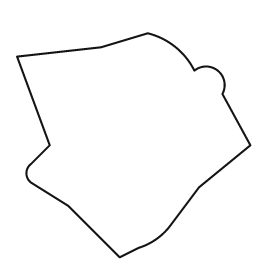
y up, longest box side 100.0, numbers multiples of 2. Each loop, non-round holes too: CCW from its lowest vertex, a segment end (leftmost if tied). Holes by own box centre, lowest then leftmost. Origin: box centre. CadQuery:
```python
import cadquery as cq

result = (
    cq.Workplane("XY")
    .moveTo(-6.0, -48.0)
    .lineTo(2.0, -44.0)
    .threePointArc((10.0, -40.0), (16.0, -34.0))
    .lineTo(28.0, -18.0)
    .lineTo(50.0, 0.0)
    .lineTo(38.0, 22.0)
    .threePointArc((36.0, 32.0), (26.0, 32.0))
    .threePointArc((18.0, 42.0), (6.0, 48.0))
    .lineTo(-14.0, 42.0)
    .lineTo(-50.0, 38.0)
    .lineTo(-36.0, 0.0)
    .lineTo(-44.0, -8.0)
    .threePointArc((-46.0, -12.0), (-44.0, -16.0))
    .lineTo(-28.0, -26.0)
    .close()
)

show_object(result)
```